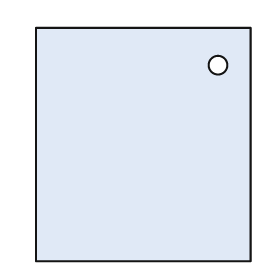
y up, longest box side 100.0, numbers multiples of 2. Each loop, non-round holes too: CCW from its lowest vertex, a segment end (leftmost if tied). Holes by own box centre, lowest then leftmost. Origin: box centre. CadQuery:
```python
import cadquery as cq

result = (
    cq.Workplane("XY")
    .moveTo(-46.0, -50.0)
    .lineTo(46.0, -50.0)
    .lineTo(46.0, 50.0)
    .lineTo(-46.0, 50.0)
    .close()
    .moveTo(32.0, 34.0)
    .circle(4.0)
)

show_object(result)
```